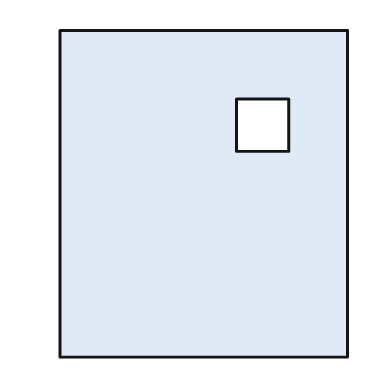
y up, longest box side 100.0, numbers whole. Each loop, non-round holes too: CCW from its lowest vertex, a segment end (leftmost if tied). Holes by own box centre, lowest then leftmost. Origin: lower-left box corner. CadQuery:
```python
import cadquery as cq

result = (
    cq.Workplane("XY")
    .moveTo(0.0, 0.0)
    .lineTo(88.0, 0.0)
    .lineTo(88.0, 100.0)
    .lineTo(0.0, 100.0)
    .close()
    .moveTo(54.0, 63.0)
    .lineTo(70.0, 63.0)
    .lineTo(70.0, 79.0)
    .lineTo(54.0, 79.0)
    .close()
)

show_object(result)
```